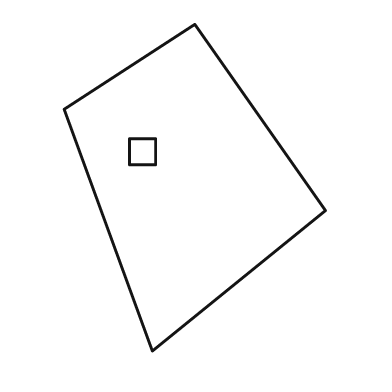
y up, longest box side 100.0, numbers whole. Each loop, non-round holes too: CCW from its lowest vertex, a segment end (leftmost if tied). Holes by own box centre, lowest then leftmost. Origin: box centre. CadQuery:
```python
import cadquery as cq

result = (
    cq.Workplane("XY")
    .moveTo(-13.0, -50.0)
    .lineTo(40.0, -7.0)
    .lineTo(0.0, 50.0)
    .lineTo(-40.0, 24.0)
    .close()
    .moveTo(-20.0, 7.0)
    .lineTo(-12.0, 7.0)
    .lineTo(-12.0, 15.0)
    .lineTo(-20.0, 15.0)
    .close()
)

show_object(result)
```